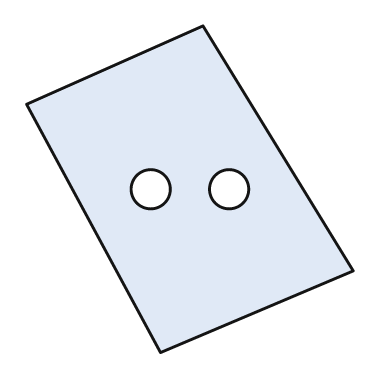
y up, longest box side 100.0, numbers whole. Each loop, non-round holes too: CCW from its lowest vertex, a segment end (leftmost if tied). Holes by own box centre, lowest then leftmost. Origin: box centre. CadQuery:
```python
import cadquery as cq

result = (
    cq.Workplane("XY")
    .moveTo(-9.0, -50.0)
    .lineTo(50.0, -25.0)
    .lineTo(4.0, 50.0)
    .lineTo(-50.0, 26.0)
    .close()
    .moveTo(-12.0, 0.0)
    .circle(6.0)
    .moveTo(12.0, 0.0)
    .circle(6.0)
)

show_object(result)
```